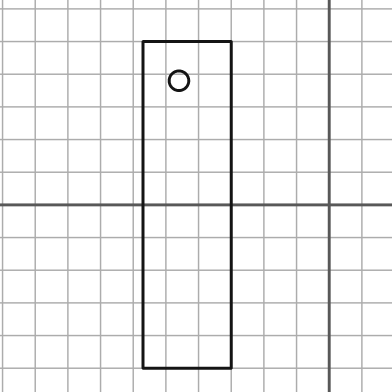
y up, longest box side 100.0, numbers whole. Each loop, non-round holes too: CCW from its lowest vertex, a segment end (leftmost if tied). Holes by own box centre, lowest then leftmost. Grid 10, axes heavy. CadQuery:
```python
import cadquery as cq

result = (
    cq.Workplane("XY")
    .moveTo(-57.0, -50.0)
    .lineTo(-30.0, -50.0)
    .lineTo(-30.0, 50.0)
    .lineTo(-57.0, 50.0)
    .close()
    .moveTo(-46.0, 38.0)
    .circle(3.0)
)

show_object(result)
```